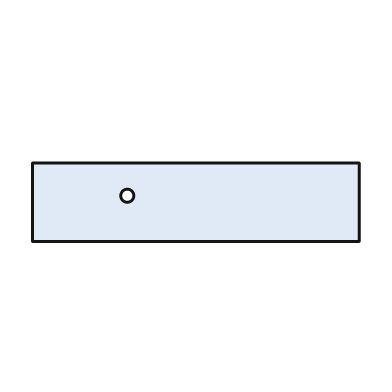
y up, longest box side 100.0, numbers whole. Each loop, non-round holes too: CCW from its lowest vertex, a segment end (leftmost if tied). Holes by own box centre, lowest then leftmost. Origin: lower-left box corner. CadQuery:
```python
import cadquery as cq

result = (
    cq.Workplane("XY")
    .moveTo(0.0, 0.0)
    .lineTo(100.0, 0.0)
    .lineTo(100.0, 24.0)
    .lineTo(0.0, 24.0)
    .close()
    .moveTo(29.0, 14.0)
    .circle(2.0)
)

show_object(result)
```